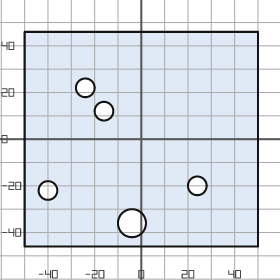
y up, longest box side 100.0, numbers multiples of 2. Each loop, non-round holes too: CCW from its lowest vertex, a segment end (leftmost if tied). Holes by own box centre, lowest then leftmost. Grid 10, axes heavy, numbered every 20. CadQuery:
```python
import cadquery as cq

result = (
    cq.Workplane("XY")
    .moveTo(-50.0, -46.0)
    .lineTo(50.0, -46.0)
    .lineTo(50.0, 46.0)
    .lineTo(-50.0, 46.0)
    .close()
    .moveTo(-4.0, -36.0)
    .circle(6.0)
    .moveTo(-40.0, -22.0)
    .circle(4.0)
    .moveTo(24.0, -20.0)
    .circle(4.0)
    .moveTo(-16.0, 12.0)
    .circle(4.0)
    .moveTo(-24.0, 22.0)
    .circle(4.0)
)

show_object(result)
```